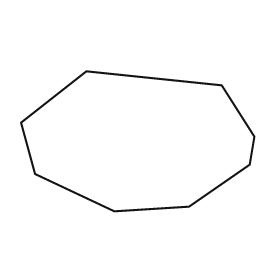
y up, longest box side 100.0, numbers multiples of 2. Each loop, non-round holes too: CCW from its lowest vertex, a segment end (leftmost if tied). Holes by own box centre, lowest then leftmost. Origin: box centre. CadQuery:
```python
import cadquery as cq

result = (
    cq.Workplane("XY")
    .moveTo(-10.0, -30.0)
    .lineTo(22.0, -28.0)
    .lineTo(48.0, -10.0)
    .lineTo(50.0, 2.0)
    .lineTo(36.0, 24.0)
    .lineTo(-22.0, 30.0)
    .lineTo(-50.0, 8.0)
    .lineTo(-44.0, -14.0)
    .close()
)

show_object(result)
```